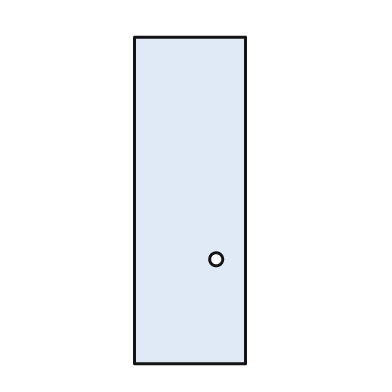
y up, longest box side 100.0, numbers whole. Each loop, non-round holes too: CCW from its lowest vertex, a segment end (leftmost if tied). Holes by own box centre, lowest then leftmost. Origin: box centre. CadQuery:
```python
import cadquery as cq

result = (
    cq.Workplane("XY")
    .moveTo(-17.0, -50.0)
    .lineTo(17.0, -50.0)
    .lineTo(17.0, 50.0)
    .lineTo(-17.0, 50.0)
    .close()
    .moveTo(8.0, -18.0)
    .circle(2.0)
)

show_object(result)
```